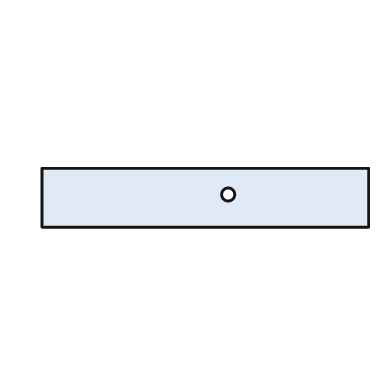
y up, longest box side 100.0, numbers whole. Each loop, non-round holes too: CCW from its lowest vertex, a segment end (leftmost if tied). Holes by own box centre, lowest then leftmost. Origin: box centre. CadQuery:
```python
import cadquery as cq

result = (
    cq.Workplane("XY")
    .moveTo(-50.0, -9.0)
    .lineTo(50.0, -9.0)
    .lineTo(50.0, 9.0)
    .lineTo(-50.0, 9.0)
    .close()
    .moveTo(7.0, 1.0)
    .circle(2.0)
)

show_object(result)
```